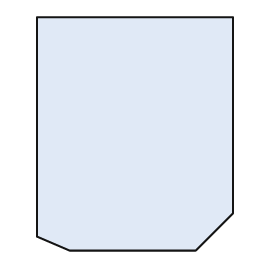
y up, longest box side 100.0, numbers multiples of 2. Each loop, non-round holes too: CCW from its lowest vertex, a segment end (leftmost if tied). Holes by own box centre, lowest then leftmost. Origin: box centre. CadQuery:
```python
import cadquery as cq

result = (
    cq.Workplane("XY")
    .moveTo(-28.0, -50.0)
    .lineTo(26.0, -50.0)
    .lineTo(42.0, -34.0)
    .lineTo(42.0, 50.0)
    .lineTo(-42.0, 50.0)
    .lineTo(-42.0, -44.0)
    .close()
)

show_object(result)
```